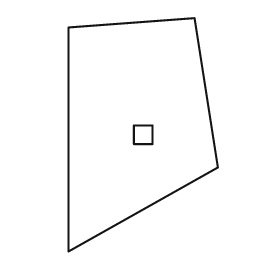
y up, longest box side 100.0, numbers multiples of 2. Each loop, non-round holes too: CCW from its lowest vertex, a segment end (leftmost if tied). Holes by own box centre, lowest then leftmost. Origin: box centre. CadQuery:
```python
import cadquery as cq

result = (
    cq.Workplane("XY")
    .moveTo(-32.0, -50.0)
    .lineTo(32.0, -14.0)
    .lineTo(22.0, 50.0)
    .lineTo(-32.0, 46.0)
    .close()
    .moveTo(-4.0, -4.0)
    .lineTo(4.0, -4.0)
    .lineTo(4.0, 4.0)
    .lineTo(-4.0, 4.0)
    .close()
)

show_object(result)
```